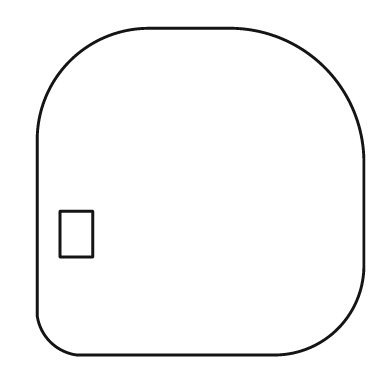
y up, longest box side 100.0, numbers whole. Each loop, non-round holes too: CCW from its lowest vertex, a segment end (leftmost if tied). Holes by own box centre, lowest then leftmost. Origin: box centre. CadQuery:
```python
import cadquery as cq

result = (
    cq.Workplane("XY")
    .moveTo(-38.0, -50.0)
    .lineTo(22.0, -50.0)
    .threePointArc((42.0, -42.0), (50.0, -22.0))
    .lineTo(50.0, 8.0)
    .threePointArc((38.0, 38.0), (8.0, 50.0))
    .lineTo(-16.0, 50.0)
    .threePointArc((-40.0, 40.0), (-50.0, 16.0))
    .lineTo(-50.0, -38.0)
    .threePointArc((-46.0, -46.0), (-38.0, -50.0))
    .close()
    .moveTo(-43.0, -20.0)
    .lineTo(-33.0, -20.0)
    .lineTo(-33.0, -6.0)
    .lineTo(-43.0, -6.0)
    .close()
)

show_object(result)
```